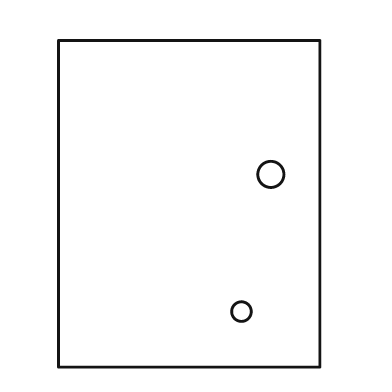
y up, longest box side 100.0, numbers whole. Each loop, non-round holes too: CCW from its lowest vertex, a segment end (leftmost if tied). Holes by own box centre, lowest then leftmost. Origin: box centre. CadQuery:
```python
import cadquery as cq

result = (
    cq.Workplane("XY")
    .moveTo(-40.0, -50.0)
    .lineTo(40.0, -50.0)
    .lineTo(40.0, 50.0)
    .lineTo(-40.0, 50.0)
    .close()
    .moveTo(16.0, -33.0)
    .circle(3.0)
    .moveTo(25.0, 9.0)
    .circle(4.0)
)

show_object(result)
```